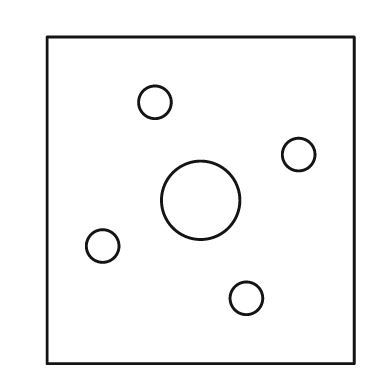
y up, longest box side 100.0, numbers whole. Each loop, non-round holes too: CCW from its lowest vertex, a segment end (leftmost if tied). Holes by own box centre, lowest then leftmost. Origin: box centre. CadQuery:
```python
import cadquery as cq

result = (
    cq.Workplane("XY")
    .moveTo(-47.0, -50.0)
    .lineTo(47.0, -50.0)
    .lineTo(47.0, 50.0)
    .lineTo(-47.0, 50.0)
    .close()
    .moveTo(14.0, -30.0)
    .circle(5.0)
    .moveTo(-30.0, -14.0)
    .circle(5.0)
    .moveTo(0.0, 0.0)
    .circle(12.0)
    .moveTo(30.0, 14.0)
    .circle(5.0)
    .moveTo(-14.0, 30.0)
    .circle(5.0)
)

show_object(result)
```